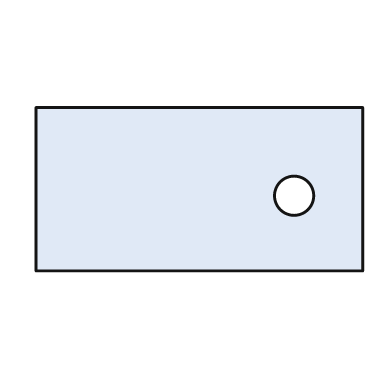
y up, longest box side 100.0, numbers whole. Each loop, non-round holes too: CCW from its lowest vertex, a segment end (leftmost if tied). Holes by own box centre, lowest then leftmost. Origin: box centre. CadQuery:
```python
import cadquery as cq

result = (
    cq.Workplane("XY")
    .moveTo(-50.0, -25.0)
    .lineTo(50.0, -25.0)
    .lineTo(50.0, 25.0)
    .lineTo(-50.0, 25.0)
    .close()
    .moveTo(29.0, -2.0)
    .circle(6.0)
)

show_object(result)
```